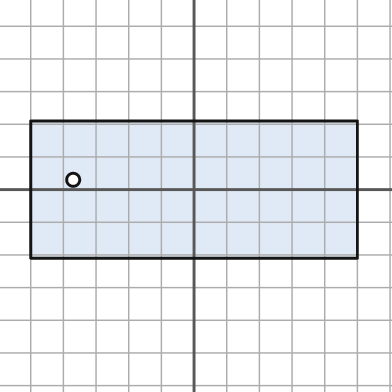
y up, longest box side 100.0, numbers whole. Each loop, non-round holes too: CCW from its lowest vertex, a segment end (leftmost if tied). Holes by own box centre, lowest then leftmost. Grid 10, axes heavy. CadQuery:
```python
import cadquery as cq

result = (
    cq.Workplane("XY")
    .moveTo(-50.0, -21.0)
    .lineTo(50.0, -21.0)
    .lineTo(50.0, 21.0)
    .lineTo(-50.0, 21.0)
    .close()
    .moveTo(-37.0, 3.0)
    .circle(2.0)
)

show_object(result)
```